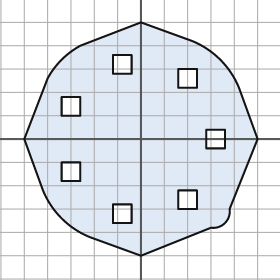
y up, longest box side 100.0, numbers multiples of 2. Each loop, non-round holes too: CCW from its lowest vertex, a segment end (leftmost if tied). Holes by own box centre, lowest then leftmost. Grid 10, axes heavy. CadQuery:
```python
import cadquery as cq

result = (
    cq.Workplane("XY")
    .moveTo(0.0, -50.0)
    .lineTo(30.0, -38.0)
    .threePointArc((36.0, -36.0), (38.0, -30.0))
    .lineTo(50.0, 0.0)
    .lineTo(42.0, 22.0)
    .threePointArc((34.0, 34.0), (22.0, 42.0))
    .lineTo(0.0, 50.0)
    .lineTo(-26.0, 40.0)
    .threePointArc((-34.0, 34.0), (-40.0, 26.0))
    .lineTo(-50.0, 0.0)
    .lineTo(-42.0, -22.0)
    .threePointArc((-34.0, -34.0), (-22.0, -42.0))
    .close()
    .moveTo(-12.0, -36.0)
    .lineTo(-4.0, -36.0)
    .lineTo(-4.0, -28.0)
    .lineTo(-12.0, -28.0)
    .close()
    .moveTo(16.0, -30.0)
    .lineTo(24.0, -30.0)
    .lineTo(24.0, -22.0)
    .lineTo(16.0, -22.0)
    .close()
    .moveTo(-34.0, -18.0)
    .lineTo(-26.0, -18.0)
    .lineTo(-26.0, -10.0)
    .lineTo(-34.0, -10.0)
    .close()
    .moveTo(28.0, -4.0)
    .lineTo(36.0, -4.0)
    .lineTo(36.0, 4.0)
    .lineTo(28.0, 4.0)
    .close()
    .moveTo(-34.0, 10.0)
    .lineTo(-26.0, 10.0)
    .lineTo(-26.0, 18.0)
    .lineTo(-34.0, 18.0)
    .close()
    .moveTo(16.0, 22.0)
    .lineTo(24.0, 22.0)
    .lineTo(24.0, 30.0)
    .lineTo(16.0, 30.0)
    .close()
    .moveTo(-12.0, 28.0)
    .lineTo(-4.0, 28.0)
    .lineTo(-4.0, 36.0)
    .lineTo(-12.0, 36.0)
    .close()
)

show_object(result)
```